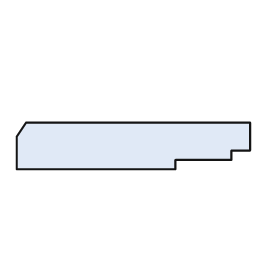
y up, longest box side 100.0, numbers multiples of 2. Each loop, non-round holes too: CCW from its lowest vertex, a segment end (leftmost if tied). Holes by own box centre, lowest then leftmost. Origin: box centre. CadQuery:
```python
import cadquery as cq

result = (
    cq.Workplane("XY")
    .moveTo(-50.0, -10.0)
    .lineTo(18.0, -10.0)
    .lineTo(18.0, -6.0)
    .lineTo(42.0, -6.0)
    .lineTo(42.0, -2.0)
    .lineTo(50.0, -2.0)
    .lineTo(50.0, 10.0)
    .lineTo(-46.0, 10.0)
    .lineTo(-50.0, 4.0)
    .close()
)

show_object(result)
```